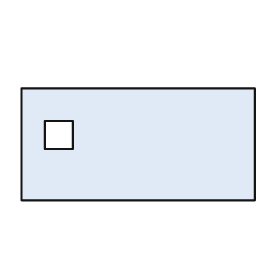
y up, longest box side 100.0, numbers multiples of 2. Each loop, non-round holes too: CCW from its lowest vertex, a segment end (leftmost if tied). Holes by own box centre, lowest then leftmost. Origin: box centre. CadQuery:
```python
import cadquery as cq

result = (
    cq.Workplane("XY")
    .moveTo(-50.0, -24.0)
    .lineTo(50.0, -24.0)
    .lineTo(50.0, 24.0)
    .lineTo(-50.0, 24.0)
    .close()
    .moveTo(-40.0, -2.0)
    .lineTo(-28.0, -2.0)
    .lineTo(-28.0, 10.0)
    .lineTo(-40.0, 10.0)
    .close()
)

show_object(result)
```